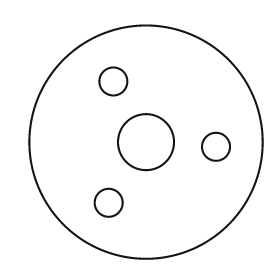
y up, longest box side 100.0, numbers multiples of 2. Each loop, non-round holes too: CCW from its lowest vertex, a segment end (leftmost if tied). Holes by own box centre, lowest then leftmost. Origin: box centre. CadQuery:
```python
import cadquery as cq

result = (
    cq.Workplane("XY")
    .moveTo(0.0, 0.0)
    .circle(50.0)
    .moveTo(-16.0, -26.0)
    .circle(6.0)
    .moveTo(30.0, -2.0)
    .circle(6.0)
    .moveTo(0.0, 0.0)
    .circle(12.0)
    .moveTo(-14.0, 26.0)
    .circle(6.0)
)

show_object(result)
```